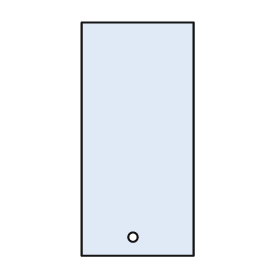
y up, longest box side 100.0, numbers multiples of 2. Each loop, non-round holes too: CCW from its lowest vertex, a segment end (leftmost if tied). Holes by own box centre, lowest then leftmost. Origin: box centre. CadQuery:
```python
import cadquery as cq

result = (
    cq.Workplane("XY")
    .moveTo(-24.0, -50.0)
    .lineTo(24.0, -50.0)
    .lineTo(24.0, 50.0)
    .lineTo(-24.0, 50.0)
    .close()
    .moveTo(-2.0, -42.0)
    .circle(2.0)
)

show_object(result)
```